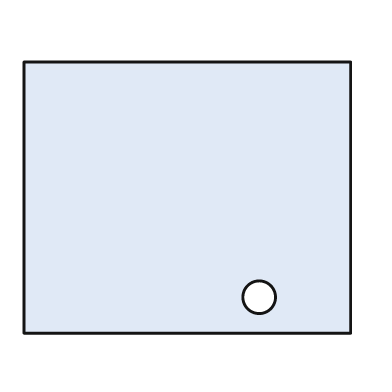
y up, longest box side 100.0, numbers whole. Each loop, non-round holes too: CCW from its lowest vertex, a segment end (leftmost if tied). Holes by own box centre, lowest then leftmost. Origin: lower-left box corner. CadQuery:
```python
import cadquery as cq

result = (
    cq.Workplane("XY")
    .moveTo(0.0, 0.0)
    .lineTo(100.0, 0.0)
    .lineTo(100.0, 83.0)
    .lineTo(0.0, 83.0)
    .close()
    .moveTo(72.0, 11.0)
    .circle(5.0)
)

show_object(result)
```